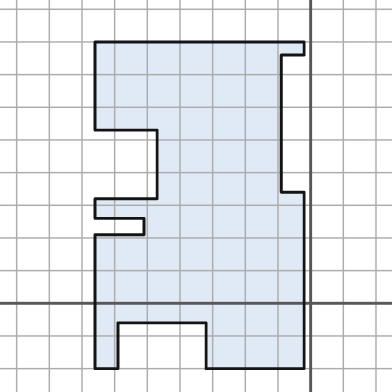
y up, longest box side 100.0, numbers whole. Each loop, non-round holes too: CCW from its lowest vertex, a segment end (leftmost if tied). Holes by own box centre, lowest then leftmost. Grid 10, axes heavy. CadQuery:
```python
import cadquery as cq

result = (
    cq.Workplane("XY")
    .moveTo(-66.0, -20.0)
    .lineTo(-59.0, -20.0)
    .lineTo(-59.0, -6.0)
    .lineTo(-32.0, -6.0)
    .lineTo(-32.0, -20.0)
    .lineTo(-2.0, -20.0)
    .lineTo(-2.0, 34.0)
    .lineTo(-9.0, 34.0)
    .lineTo(-9.0, 76.0)
    .lineTo(-2.0, 76.0)
    .lineTo(-2.0, 80.0)
    .lineTo(-66.0, 80.0)
    .lineTo(-66.0, 53.0)
    .lineTo(-47.0, 53.0)
    .lineTo(-47.0, 32.0)
    .lineTo(-66.0, 32.0)
    .lineTo(-66.0, 26.0)
    .lineTo(-51.0, 26.0)
    .lineTo(-51.0, 21.0)
    .lineTo(-66.0, 21.0)
    .close()
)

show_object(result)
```